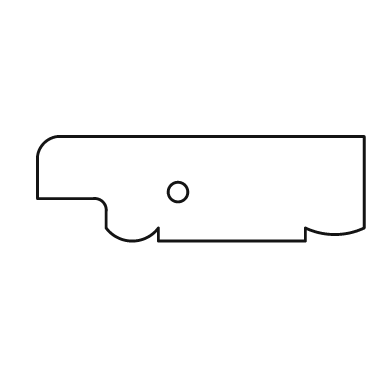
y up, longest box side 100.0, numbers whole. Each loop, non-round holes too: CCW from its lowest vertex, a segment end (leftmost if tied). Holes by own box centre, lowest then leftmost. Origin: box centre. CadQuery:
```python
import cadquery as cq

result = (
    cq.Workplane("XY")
    .moveTo(-13.0, -16.0)
    .lineTo(32.0, -16.0)
    .lineTo(32.0, -12.0)
    .threePointArc((41.0, -14.0), (50.0, -12.0))
    .lineTo(50.0, 16.0)
    .lineTo(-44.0, 16.0)
    .threePointArc((-48.0, 14.0), (-50.0, 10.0))
    .lineTo(-50.0, -3.0)
    .lineTo(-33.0, -3.0)
    .threePointArc((-30.0, -4.0), (-29.0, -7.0))
    .lineTo(-29.0, -12.0)
    .threePointArc((-21.0, -16.0), (-13.0, -12.0))
    .close()
    .moveTo(-7.0, -1.0)
    .circle(3.0)
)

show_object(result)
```